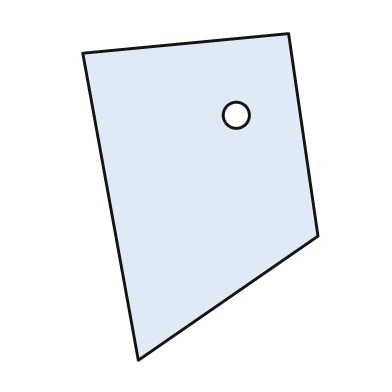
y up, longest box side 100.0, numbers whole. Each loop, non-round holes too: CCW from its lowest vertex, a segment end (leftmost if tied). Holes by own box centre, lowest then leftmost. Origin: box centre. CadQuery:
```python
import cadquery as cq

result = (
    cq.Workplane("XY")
    .moveTo(-19.0, -50.0)
    .lineTo(36.0, -12.0)
    .lineTo(27.0, 50.0)
    .lineTo(-36.0, 44.0)
    .close()
    .moveTo(11.0, 25.0)
    .circle(4.0)
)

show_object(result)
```